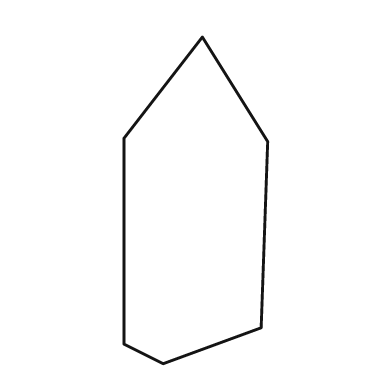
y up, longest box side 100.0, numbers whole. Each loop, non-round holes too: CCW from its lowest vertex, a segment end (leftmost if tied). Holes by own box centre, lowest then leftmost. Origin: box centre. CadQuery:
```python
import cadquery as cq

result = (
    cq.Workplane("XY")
    .moveTo(-10.0, -50.0)
    .lineTo(20.0, -39.0)
    .lineTo(22.0, 18.0)
    .lineTo(2.0, 50.0)
    .lineTo(-22.0, 19.0)
    .lineTo(-22.0, -44.0)
    .close()
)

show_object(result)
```